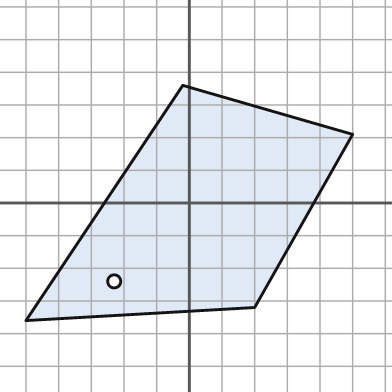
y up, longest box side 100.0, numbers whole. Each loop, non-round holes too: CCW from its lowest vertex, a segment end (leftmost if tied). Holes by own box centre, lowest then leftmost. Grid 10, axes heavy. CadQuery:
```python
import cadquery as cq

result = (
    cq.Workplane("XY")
    .moveTo(-50.0, -36.0)
    .lineTo(20.0, -32.0)
    .lineTo(50.0, 21.0)
    .lineTo(-2.0, 36.0)
    .close()
    .moveTo(-23.0, -24.0)
    .circle(2.0)
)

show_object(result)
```